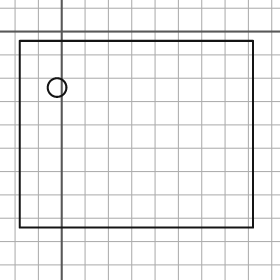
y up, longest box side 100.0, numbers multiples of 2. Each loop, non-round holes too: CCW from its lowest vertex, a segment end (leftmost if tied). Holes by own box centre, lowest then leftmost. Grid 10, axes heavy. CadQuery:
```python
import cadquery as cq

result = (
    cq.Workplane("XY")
    .moveTo(-18.0, -84.0)
    .lineTo(82.0, -84.0)
    .lineTo(82.0, -4.0)
    .lineTo(-18.0, -4.0)
    .close()
    .moveTo(-2.0, -24.0)
    .circle(4.0)
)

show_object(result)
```